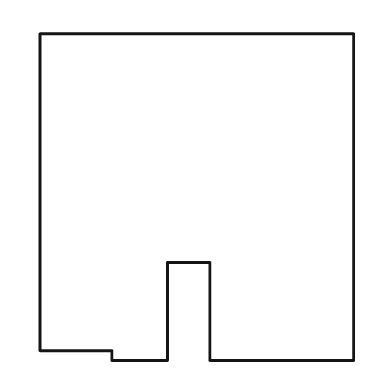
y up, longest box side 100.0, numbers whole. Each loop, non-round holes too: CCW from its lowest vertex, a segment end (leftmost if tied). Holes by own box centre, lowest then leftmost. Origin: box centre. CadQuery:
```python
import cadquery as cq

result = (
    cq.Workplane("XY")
    .moveTo(-26.0, -50.0)
    .lineTo(-9.0, -50.0)
    .lineTo(-9.0, -20.0)
    .lineTo(4.0, -20.0)
    .lineTo(4.0, -50.0)
    .lineTo(48.0, -50.0)
    .lineTo(48.0, 50.0)
    .lineTo(-48.0, 50.0)
    .lineTo(-48.0, -47.0)
    .lineTo(-26.0, -47.0)
    .close()
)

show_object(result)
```